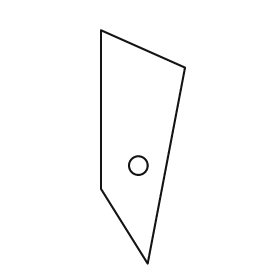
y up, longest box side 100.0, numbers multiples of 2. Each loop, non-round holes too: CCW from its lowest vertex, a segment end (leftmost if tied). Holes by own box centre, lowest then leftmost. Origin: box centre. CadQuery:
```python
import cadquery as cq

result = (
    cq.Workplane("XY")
    .moveTo(2.0, -50.0)
    .lineTo(18.0, 34.0)
    .lineTo(-18.0, 50.0)
    .lineTo(-18.0, -18.0)
    .close()
    .moveTo(-2.0, -8.0)
    .circle(4.0)
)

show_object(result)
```